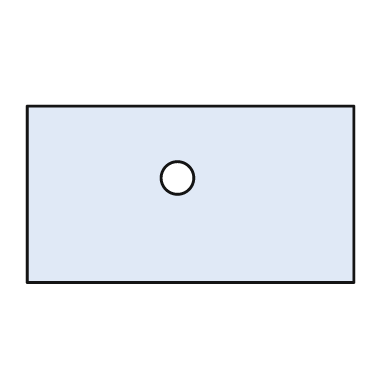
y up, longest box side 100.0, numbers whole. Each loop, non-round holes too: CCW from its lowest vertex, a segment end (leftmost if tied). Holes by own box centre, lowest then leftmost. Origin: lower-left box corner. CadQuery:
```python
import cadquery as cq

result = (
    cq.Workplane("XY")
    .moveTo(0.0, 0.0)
    .lineTo(100.0, 0.0)
    .lineTo(100.0, 54.0)
    .lineTo(0.0, 54.0)
    .close()
    .moveTo(46.0, 32.0)
    .circle(5.0)
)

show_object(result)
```